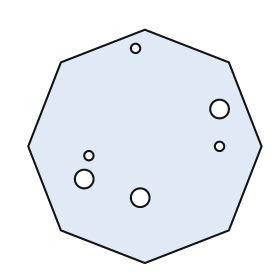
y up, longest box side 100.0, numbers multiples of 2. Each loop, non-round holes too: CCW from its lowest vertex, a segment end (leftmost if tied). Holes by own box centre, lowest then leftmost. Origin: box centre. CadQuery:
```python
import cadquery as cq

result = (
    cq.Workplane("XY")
    .moveTo(0.0, -50.0)
    .lineTo(36.0, -36.0)
    .lineTo(50.0, 0.0)
    .lineTo(36.0, 36.0)
    .lineTo(0.0, 50.0)
    .lineTo(-36.0, 36.0)
    .lineTo(-50.0, 0.0)
    .lineTo(-36.0, -36.0)
    .close()
    .moveTo(-2.0, -22.0)
    .circle(4.0)
    .moveTo(-26.0, -14.0)
    .circle(4.0)
    .moveTo(-24.0, -4.0)
    .circle(2.0)
    .moveTo(32.0, 0.0)
    .circle(2.0)
    .moveTo(32.0, 16.0)
    .circle(4.0)
    .moveTo(-4.0, 42.0)
    .circle(2.0)
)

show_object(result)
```